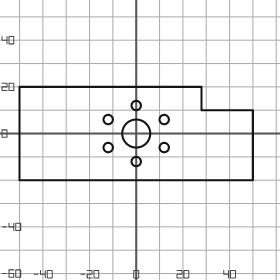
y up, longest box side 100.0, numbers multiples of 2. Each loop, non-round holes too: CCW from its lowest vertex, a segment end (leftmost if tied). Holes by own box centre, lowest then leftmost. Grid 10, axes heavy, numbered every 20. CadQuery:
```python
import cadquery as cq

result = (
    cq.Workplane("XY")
    .moveTo(-50.0, -20.0)
    .lineTo(50.0, -20.0)
    .lineTo(50.0, 10.0)
    .lineTo(28.0, 10.0)
    .lineTo(28.0, 20.0)
    .lineTo(-50.0, 20.0)
    .close()
    .moveTo(0.0, -12.0)
    .circle(2.0)
    .moveTo(-12.0, -6.0)
    .circle(2.0)
    .moveTo(12.0, -6.0)
    .circle(2.0)
    .moveTo(0.0, 0.0)
    .circle(6.0)
    .moveTo(-12.0, 6.0)
    .circle(2.0)
    .moveTo(12.0, 6.0)
    .circle(2.0)
    .moveTo(0.0, 12.0)
    .circle(2.0)
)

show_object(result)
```